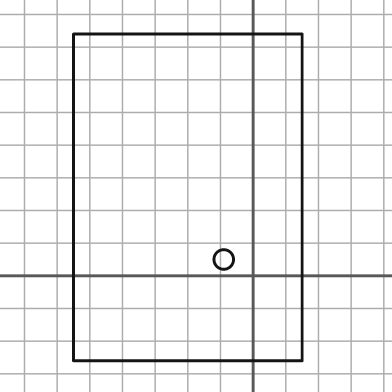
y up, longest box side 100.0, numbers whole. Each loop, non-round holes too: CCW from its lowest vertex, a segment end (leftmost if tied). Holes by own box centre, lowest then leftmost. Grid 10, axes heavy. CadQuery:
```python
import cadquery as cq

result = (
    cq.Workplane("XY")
    .moveTo(-55.0, -26.0)
    .lineTo(15.0, -26.0)
    .lineTo(15.0, 74.0)
    .lineTo(-55.0, 74.0)
    .close()
    .moveTo(-9.0, 5.0)
    .circle(3.0)
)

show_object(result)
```